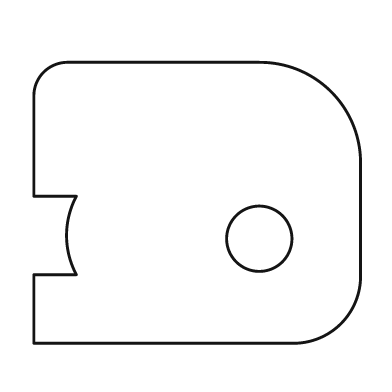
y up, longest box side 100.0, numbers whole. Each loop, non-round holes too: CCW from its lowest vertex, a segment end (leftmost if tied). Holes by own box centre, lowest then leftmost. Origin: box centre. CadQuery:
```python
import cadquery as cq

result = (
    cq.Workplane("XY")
    .moveTo(-50.0, -43.0)
    .lineTo(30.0, -43.0)
    .threePointArc((44.0, -37.0), (50.0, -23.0))
    .lineTo(50.0, 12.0)
    .threePointArc((41.0, 34.0), (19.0, 43.0))
    .lineTo(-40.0, 43.0)
    .threePointArc((-47.0, 40.0), (-50.0, 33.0))
    .lineTo(-50.0, 2.0)
    .lineTo(-37.0, 2.0)
    .threePointArc((-40.0, -10.0), (-37.0, -22.0))
    .lineTo(-50.0, -22.0)
    .close()
    .moveTo(19.0, -11.0)
    .circle(10.0)
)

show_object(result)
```